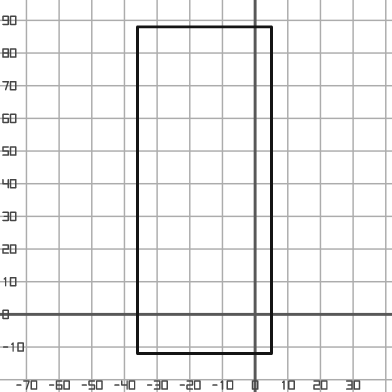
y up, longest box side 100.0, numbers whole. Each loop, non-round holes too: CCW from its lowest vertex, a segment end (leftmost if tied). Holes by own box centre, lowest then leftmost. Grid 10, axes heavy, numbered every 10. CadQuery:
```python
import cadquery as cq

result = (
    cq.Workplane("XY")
    .moveTo(-36.0, -12.0)
    .lineTo(5.0, -12.0)
    .lineTo(5.0, 88.0)
    .lineTo(-36.0, 88.0)
    .close()
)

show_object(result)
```